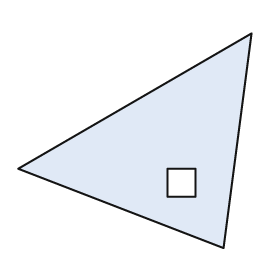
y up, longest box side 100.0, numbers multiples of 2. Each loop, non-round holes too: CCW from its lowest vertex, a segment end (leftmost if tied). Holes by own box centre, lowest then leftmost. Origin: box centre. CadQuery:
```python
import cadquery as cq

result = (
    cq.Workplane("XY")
    .moveTo(38.0, -46.0)
    .lineTo(50.0, 46.0)
    .lineTo(-50.0, -12.0)
    .close()
    .moveTo(14.0, -24.0)
    .lineTo(26.0, -24.0)
    .lineTo(26.0, -12.0)
    .lineTo(14.0, -12.0)
    .close()
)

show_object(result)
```